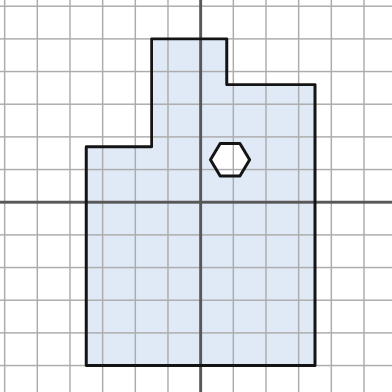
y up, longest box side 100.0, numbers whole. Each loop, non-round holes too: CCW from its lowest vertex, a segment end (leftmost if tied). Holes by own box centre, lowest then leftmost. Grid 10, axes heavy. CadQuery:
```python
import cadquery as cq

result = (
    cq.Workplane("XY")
    .moveTo(-35.0, -50.0)
    .lineTo(35.0, -50.0)
    .lineTo(35.0, 36.0)
    .lineTo(8.0, 36.0)
    .lineTo(8.0, 50.0)
    .lineTo(-15.0, 50.0)
    .lineTo(-15.0, 17.0)
    .lineTo(-35.0, 17.0)
    .close()
    .moveTo(6.0, 8.0)
    .lineTo(12.0, 8.0)
    .lineTo(15.0, 13.0)
    .lineTo(12.0, 18.0)
    .lineTo(6.0, 18.0)
    .lineTo(3.0, 13.0)
    .close()
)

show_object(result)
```